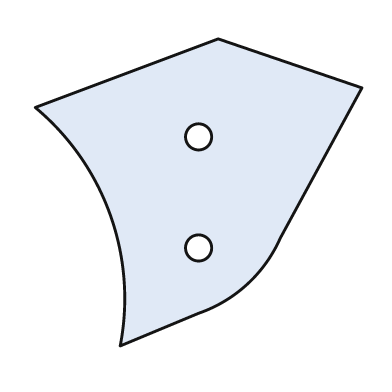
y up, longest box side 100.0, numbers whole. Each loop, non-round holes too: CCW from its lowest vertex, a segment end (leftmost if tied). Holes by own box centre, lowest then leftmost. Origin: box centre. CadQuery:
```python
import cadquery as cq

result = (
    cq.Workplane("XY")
    .moveTo(-24.0, -47.0)
    .lineTo(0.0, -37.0)
    .threePointArc((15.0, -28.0), (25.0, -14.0))
    .lineTo(50.0, 32.0)
    .lineTo(6.0, 47.0)
    .lineTo(-50.0, 26.0)
    .threePointArc((-27.0, -7.0), (-24.0, -47.0))
    .close()
    .moveTo(0.0, -17.0)
    .circle(4.0)
    .moveTo(0.0, 17.0)
    .circle(4.0)
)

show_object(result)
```